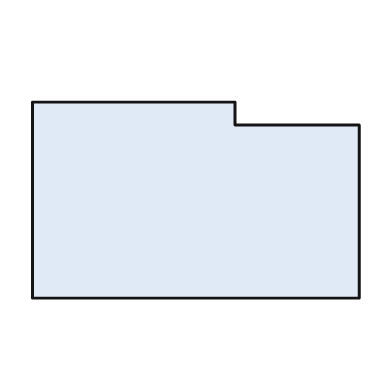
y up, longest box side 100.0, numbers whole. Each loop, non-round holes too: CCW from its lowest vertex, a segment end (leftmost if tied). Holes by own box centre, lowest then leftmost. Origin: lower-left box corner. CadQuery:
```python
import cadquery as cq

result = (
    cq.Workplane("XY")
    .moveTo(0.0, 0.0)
    .lineTo(100.0, 0.0)
    .lineTo(100.0, 53.0)
    .lineTo(62.0, 53.0)
    .lineTo(62.0, 60.0)
    .lineTo(0.0, 60.0)
    .close()
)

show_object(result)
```